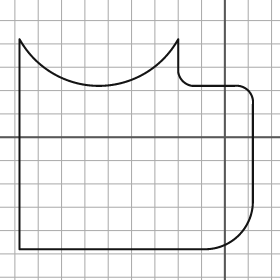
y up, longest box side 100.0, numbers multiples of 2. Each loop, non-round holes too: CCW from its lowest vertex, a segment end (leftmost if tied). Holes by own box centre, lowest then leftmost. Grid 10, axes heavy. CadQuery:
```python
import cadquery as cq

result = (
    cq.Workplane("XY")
    .moveTo(-88.0, -48.0)
    .lineTo(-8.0, -48.0)
    .threePointArc((6.0, -42.0), (12.0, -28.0))
    .lineTo(12.0, 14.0)
    .threePointArc((10.0, 20.0), (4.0, 22.0))
    .lineTo(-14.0, 22.0)
    .threePointArc((-18.0, 24.0), (-20.0, 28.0))
    .lineTo(-20.0, 42.0)
    .threePointArc((-54.0, 22.0), (-88.0, 42.0))
    .close()
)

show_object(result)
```